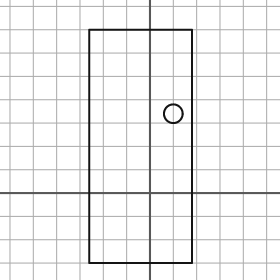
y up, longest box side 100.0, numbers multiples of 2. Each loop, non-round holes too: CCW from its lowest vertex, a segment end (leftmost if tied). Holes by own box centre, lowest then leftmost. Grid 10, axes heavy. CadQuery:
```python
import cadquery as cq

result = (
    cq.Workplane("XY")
    .moveTo(-26.0, -30.0)
    .lineTo(18.0, -30.0)
    .lineTo(18.0, 70.0)
    .lineTo(-26.0, 70.0)
    .close()
    .moveTo(10.0, 34.0)
    .circle(4.0)
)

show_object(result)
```